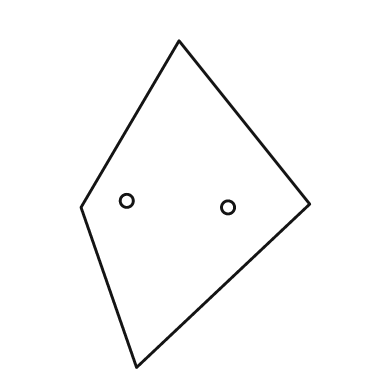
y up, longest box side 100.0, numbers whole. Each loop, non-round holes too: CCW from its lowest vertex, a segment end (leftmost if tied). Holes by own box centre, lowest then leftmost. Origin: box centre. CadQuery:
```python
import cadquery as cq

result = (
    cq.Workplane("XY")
    .moveTo(-18.0, -50.0)
    .lineTo(35.0, 0.0)
    .lineTo(-5.0, 50.0)
    .lineTo(-35.0, -1.0)
    .close()
    .moveTo(10.0, -1.0)
    .circle(2.0)
    .moveTo(-21.0, 1.0)
    .circle(2.0)
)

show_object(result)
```